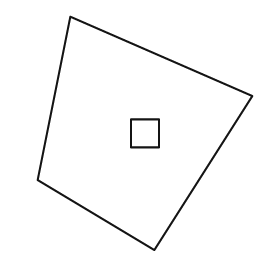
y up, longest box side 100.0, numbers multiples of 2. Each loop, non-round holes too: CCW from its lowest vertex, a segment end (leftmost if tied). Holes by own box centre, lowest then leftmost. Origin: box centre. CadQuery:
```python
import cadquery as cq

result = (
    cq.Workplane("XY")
    .moveTo(4.0, -50.0)
    .lineTo(46.0, 16.0)
    .lineTo(-32.0, 50.0)
    .lineTo(-46.0, -20.0)
    .close()
    .moveTo(-6.0, -6.0)
    .lineTo(6.0, -6.0)
    .lineTo(6.0, 6.0)
    .lineTo(-6.0, 6.0)
    .close()
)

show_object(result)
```